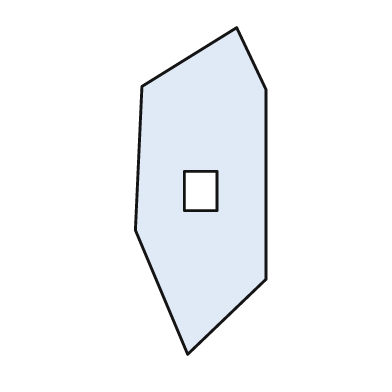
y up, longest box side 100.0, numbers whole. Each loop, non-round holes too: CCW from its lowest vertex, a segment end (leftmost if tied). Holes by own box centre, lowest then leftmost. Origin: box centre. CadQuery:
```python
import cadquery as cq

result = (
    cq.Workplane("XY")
    .moveTo(-4.0, -50.0)
    .lineTo(20.0, -27.0)
    .lineTo(20.0, 31.0)
    .lineTo(11.0, 50.0)
    .lineTo(-18.0, 32.0)
    .lineTo(-20.0, -12.0)
    .close()
    .moveTo(-5.0, -6.0)
    .lineTo(5.0, -6.0)
    .lineTo(5.0, 6.0)
    .lineTo(-5.0, 6.0)
    .close()
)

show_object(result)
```